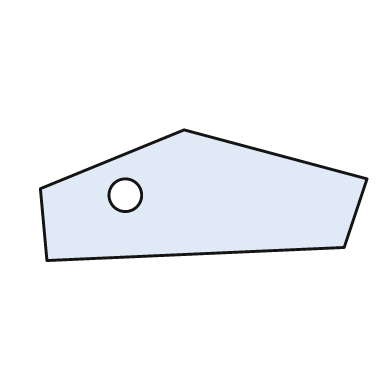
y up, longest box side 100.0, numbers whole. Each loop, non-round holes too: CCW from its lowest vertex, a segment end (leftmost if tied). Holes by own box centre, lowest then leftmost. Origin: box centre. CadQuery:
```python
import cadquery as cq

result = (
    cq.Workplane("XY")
    .moveTo(-48.0, -20.0)
    .lineTo(43.0, -16.0)
    .lineTo(50.0, 5.0)
    .lineTo(-6.0, 20.0)
    .lineTo(-50.0, 2.0)
    .close()
    .moveTo(-24.0, 0.0)
    .circle(5.0)
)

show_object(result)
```